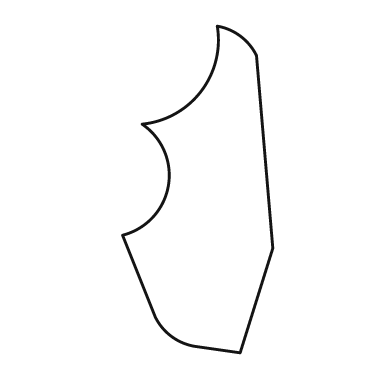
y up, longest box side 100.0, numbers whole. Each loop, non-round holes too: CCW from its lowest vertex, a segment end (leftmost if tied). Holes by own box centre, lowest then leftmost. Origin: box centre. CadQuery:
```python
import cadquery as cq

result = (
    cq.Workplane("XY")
    .moveTo(13.0, -50.0)
    .lineTo(23.0, -18.0)
    .lineTo(18.0, 41.0)
    .threePointArc((13.0, 47.0), (6.0, 50.0))
    .threePointArc((1.0, 30.0), (-17.0, 20.0))
    .threePointArc((-9.0, 1.0), (-23.0, -14.0))
    .lineTo(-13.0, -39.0)
    .threePointArc((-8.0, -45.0), (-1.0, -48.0))
    .close()
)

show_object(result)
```